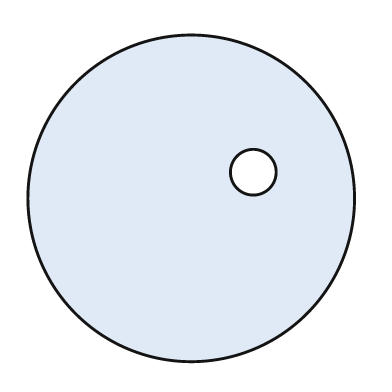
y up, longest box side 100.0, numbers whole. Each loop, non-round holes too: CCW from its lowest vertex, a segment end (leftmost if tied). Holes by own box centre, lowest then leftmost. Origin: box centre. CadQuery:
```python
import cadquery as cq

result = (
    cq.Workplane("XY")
    .moveTo(0.0, 0.0)
    .circle(50.0)
    .moveTo(19.0, 8.0)
    .circle(7.0)
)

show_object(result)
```